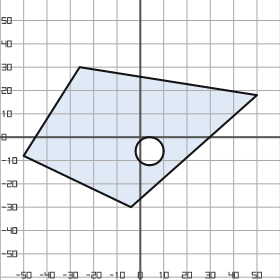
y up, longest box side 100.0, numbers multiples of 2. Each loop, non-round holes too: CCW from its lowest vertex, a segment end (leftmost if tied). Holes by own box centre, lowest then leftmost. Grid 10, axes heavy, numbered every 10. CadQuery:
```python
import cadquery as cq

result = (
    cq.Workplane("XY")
    .moveTo(-4.0, -30.0)
    .lineTo(50.0, 18.0)
    .lineTo(-26.0, 30.0)
    .lineTo(-50.0, -8.0)
    .close()
    .moveTo(4.0, -6.0)
    .circle(6.0)
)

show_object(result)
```